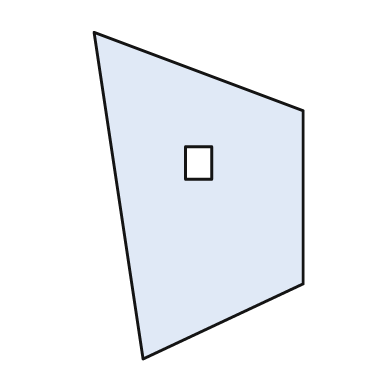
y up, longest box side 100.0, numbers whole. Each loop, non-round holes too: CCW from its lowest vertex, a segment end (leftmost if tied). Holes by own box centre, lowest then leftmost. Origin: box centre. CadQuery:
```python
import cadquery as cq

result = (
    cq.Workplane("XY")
    .moveTo(-17.0, -50.0)
    .lineTo(32.0, -27.0)
    .lineTo(32.0, 26.0)
    .lineTo(-32.0, 50.0)
    .close()
    .moveTo(-4.0, 5.0)
    .lineTo(4.0, 5.0)
    .lineTo(4.0, 15.0)
    .lineTo(-4.0, 15.0)
    .close()
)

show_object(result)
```